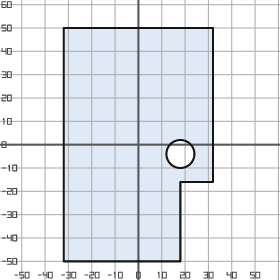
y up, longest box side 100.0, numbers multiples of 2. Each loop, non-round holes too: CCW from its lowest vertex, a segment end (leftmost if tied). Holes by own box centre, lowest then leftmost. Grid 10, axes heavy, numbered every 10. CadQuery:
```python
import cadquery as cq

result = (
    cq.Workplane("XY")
    .moveTo(-32.0, -50.0)
    .lineTo(18.0, -50.0)
    .lineTo(18.0, -16.0)
    .lineTo(32.0, -16.0)
    .lineTo(32.0, 50.0)
    .lineTo(-32.0, 50.0)
    .close()
    .moveTo(18.0, -4.0)
    .circle(6.0)
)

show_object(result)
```